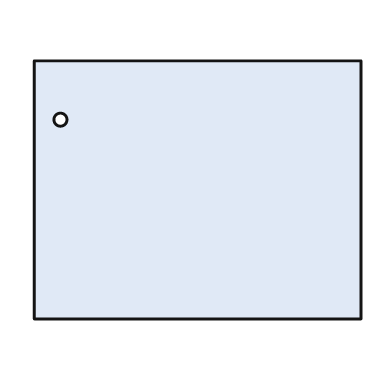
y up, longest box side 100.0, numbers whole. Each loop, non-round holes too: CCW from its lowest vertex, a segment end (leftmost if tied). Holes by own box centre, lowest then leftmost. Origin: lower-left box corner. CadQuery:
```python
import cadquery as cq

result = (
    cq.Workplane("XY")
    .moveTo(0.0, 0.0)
    .lineTo(100.0, 0.0)
    .lineTo(100.0, 79.0)
    .lineTo(0.0, 79.0)
    .close()
    .moveTo(8.0, 61.0)
    .circle(2.0)
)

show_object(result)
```